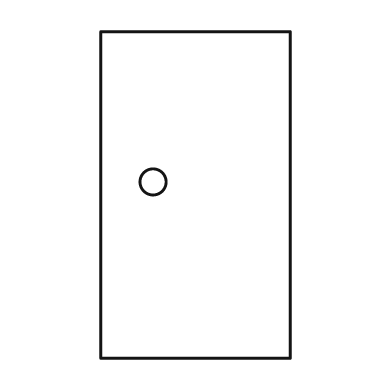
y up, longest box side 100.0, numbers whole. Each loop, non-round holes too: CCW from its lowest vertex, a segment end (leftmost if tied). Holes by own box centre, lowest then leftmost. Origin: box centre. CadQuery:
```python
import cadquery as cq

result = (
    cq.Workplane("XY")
    .moveTo(-29.0, -50.0)
    .lineTo(29.0, -50.0)
    .lineTo(29.0, 50.0)
    .lineTo(-29.0, 50.0)
    .close()
    .moveTo(-13.0, 4.0)
    .circle(4.0)
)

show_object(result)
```